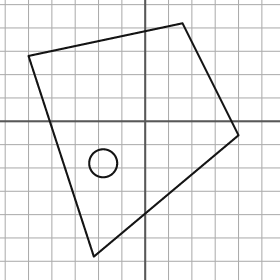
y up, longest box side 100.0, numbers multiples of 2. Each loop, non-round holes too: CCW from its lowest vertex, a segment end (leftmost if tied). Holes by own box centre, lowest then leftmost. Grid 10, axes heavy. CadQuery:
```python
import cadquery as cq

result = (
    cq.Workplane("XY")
    .moveTo(-22.0, -58.0)
    .lineTo(40.0, -6.0)
    .lineTo(16.0, 42.0)
    .lineTo(-50.0, 28.0)
    .close()
    .moveTo(-18.0, -18.0)
    .circle(6.0)
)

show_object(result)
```